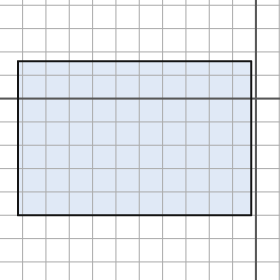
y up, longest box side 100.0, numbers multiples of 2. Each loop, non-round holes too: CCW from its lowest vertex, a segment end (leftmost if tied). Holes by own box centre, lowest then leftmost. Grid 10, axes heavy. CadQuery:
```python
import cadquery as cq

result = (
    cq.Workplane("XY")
    .moveTo(-102.0, -50.0)
    .lineTo(-2.0, -50.0)
    .lineTo(-2.0, 16.0)
    .lineTo(-102.0, 16.0)
    .close()
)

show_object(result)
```